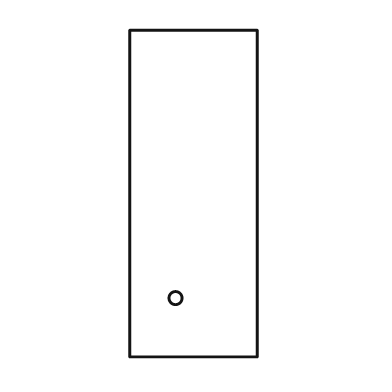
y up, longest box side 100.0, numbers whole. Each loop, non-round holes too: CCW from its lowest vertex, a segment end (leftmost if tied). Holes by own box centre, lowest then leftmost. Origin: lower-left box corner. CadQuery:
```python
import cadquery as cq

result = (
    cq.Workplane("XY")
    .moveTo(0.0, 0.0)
    .lineTo(39.0, 0.0)
    .lineTo(39.0, 100.0)
    .lineTo(0.0, 100.0)
    .close()
    .moveTo(14.0, 18.0)
    .circle(2.0)
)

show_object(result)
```